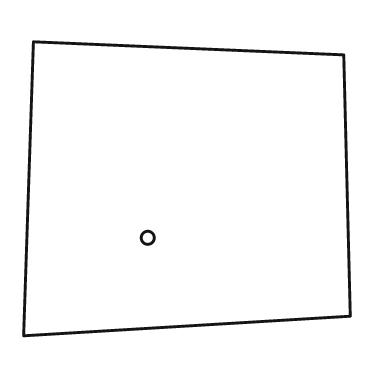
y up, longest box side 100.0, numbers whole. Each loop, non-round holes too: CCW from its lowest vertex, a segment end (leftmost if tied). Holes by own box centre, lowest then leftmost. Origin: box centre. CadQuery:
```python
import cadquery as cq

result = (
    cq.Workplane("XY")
    .moveTo(-50.0, -45.0)
    .lineTo(50.0, -39.0)
    .lineTo(48.0, 41.0)
    .lineTo(-47.0, 45.0)
    .close()
    .moveTo(-12.0, -15.0)
    .circle(2.0)
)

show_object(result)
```